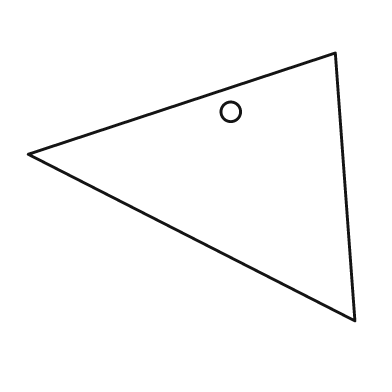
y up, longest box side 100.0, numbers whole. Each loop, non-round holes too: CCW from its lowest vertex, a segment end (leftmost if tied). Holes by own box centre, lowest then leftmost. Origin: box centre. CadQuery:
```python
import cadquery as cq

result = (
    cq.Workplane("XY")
    .moveTo(50.0, -41.0)
    .lineTo(44.0, 41.0)
    .lineTo(-50.0, 10.0)
    .close()
    .moveTo(12.0, 23.0)
    .circle(3.0)
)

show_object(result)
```